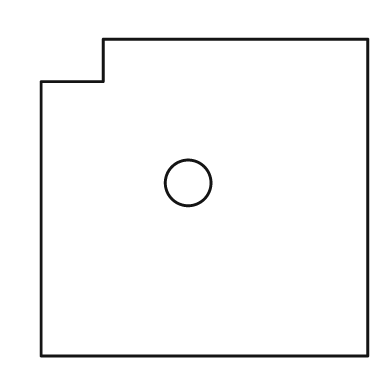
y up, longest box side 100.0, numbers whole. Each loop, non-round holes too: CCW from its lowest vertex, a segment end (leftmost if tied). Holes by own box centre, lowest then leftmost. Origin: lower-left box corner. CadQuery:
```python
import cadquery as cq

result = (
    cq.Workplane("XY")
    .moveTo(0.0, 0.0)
    .lineTo(100.0, 0.0)
    .lineTo(100.0, 97.0)
    .lineTo(19.0, 97.0)
    .lineTo(19.0, 84.0)
    .lineTo(0.0, 84.0)
    .close()
    .moveTo(45.0, 53.0)
    .circle(7.0)
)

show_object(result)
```